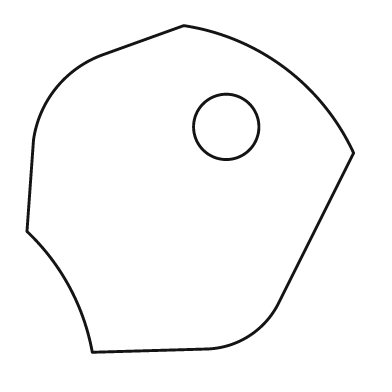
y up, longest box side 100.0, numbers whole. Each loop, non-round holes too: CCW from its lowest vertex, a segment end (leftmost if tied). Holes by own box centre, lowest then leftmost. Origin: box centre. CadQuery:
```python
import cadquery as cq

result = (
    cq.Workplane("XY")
    .moveTo(-30.0, -50.0)
    .lineTo(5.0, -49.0)
    .threePointArc((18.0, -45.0), (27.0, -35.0))
    .lineTo(50.0, 11.0)
    .threePointArc((29.0, 37.0), (-2.0, 50.0))
    .lineTo(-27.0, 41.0)
    .threePointArc((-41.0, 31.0), (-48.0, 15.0))
    .lineTo(-50.0, -13.0)
    .threePointArc((-37.0, -30.0), (-30.0, -50.0))
    .close()
    .moveTo(11.0, 19.0)
    .circle(10.0)
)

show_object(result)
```